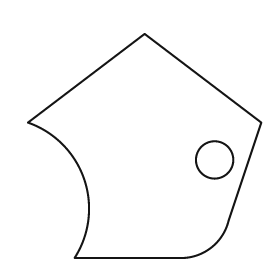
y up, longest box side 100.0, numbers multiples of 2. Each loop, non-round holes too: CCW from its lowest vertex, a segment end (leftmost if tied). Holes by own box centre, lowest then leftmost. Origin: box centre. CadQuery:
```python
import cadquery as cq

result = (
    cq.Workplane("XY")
    .moveTo(-30.0, -48.0)
    .lineTo(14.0, -48.0)
    .threePointArc((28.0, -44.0), (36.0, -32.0))
    .lineTo(50.0, 10.0)
    .lineTo(0.0, 48.0)
    .lineTo(-50.0, 10.0)
    .threePointArc((-26.0, -14.0), (-30.0, -48.0))
    .close()
    .moveTo(30.0, -6.0)
    .circle(8.0)
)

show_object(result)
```